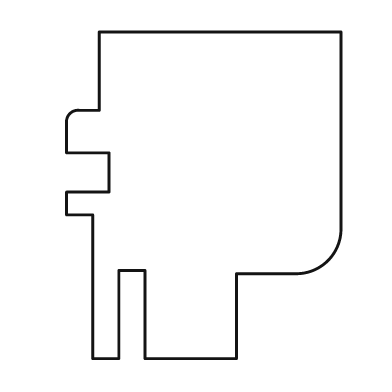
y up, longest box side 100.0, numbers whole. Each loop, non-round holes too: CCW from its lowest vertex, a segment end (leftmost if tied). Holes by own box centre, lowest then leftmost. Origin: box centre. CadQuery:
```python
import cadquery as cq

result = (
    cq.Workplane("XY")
    .moveTo(-34.0, -50.0)
    .lineTo(-26.0, -50.0)
    .lineTo(-26.0, -23.0)
    .lineTo(-18.0, -23.0)
    .lineTo(-18.0, -50.0)
    .lineTo(10.0, -50.0)
    .lineTo(10.0, -24.0)
    .lineTo(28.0, -24.0)
    .threePointArc((38.0, -20.0), (42.0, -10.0))
    .lineTo(42.0, 50.0)
    .lineTo(-32.0, 50.0)
    .lineTo(-32.0, 26.0)
    .lineTo(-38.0, 26.0)
    .threePointArc((-41.0, 25.0), (-42.0, 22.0))
    .lineTo(-42.0, 13.0)
    .lineTo(-29.0, 13.0)
    .lineTo(-29.0, 1.0)
    .lineTo(-42.0, 1.0)
    .lineTo(-42.0, -6.0)
    .lineTo(-34.0, -6.0)
    .close()
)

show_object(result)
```